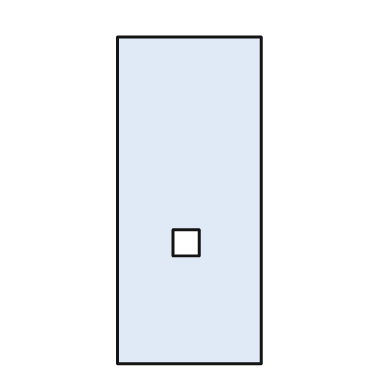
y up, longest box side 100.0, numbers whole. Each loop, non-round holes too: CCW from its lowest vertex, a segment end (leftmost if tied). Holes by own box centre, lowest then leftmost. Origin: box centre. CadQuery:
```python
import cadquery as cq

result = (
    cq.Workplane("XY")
    .moveTo(-22.0, -50.0)
    .lineTo(22.0, -50.0)
    .lineTo(22.0, 50.0)
    .lineTo(-22.0, 50.0)
    .close()
    .moveTo(-5.0, -17.0)
    .lineTo(3.0, -17.0)
    .lineTo(3.0, -9.0)
    .lineTo(-5.0, -9.0)
    .close()
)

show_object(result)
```